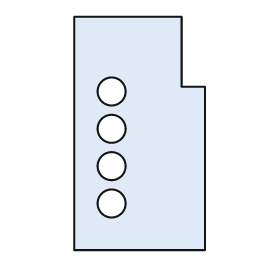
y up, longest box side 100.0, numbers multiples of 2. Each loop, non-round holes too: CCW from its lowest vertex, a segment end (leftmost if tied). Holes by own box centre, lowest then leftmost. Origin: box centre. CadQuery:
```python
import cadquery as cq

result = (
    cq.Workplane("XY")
    .moveTo(-28.0, -50.0)
    .lineTo(28.0, -50.0)
    .lineTo(28.0, 20.0)
    .lineTo(18.0, 20.0)
    .lineTo(18.0, 50.0)
    .lineTo(-28.0, 50.0)
    .close()
    .moveTo(-12.0, -30.0)
    .circle(6.0)
    .moveTo(-12.0, -14.0)
    .circle(6.0)
    .moveTo(-12.0, 2.0)
    .circle(6.0)
    .moveTo(-12.0, 18.0)
    .circle(6.0)
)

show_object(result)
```